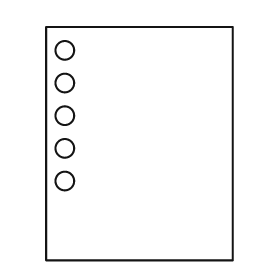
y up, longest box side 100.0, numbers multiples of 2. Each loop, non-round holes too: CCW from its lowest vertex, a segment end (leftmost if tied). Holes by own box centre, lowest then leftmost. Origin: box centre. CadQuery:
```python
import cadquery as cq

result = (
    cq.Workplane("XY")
    .moveTo(-40.0, -50.0)
    .lineTo(40.0, -50.0)
    .lineTo(40.0, 50.0)
    .lineTo(-40.0, 50.0)
    .close()
    .moveTo(-32.0, -16.0)
    .circle(4.0)
    .moveTo(-32.0, -2.0)
    .circle(4.0)
    .moveTo(-32.0, 12.0)
    .circle(4.0)
    .moveTo(-32.0, 26.0)
    .circle(4.0)
    .moveTo(-32.0, 40.0)
    .circle(4.0)
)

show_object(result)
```